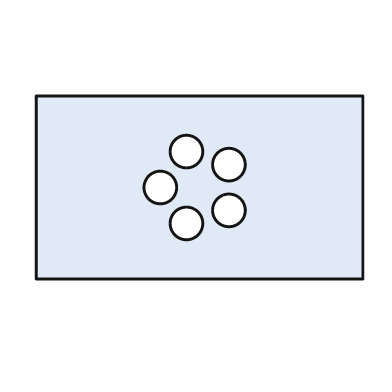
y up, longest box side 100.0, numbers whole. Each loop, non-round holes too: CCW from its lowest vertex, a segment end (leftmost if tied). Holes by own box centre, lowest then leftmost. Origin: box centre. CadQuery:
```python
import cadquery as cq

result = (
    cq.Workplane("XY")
    .moveTo(-50.0, -28.0)
    .lineTo(50.0, -28.0)
    .lineTo(50.0, 28.0)
    .lineTo(-50.0, 28.0)
    .close()
    .moveTo(-4.0, -11.0)
    .circle(5.0)
    .moveTo(9.0, -7.0)
    .circle(5.0)
    .moveTo(-12.0, 0.0)
    .circle(5.0)
    .moveTo(9.0, 7.0)
    .circle(5.0)
    .moveTo(-4.0, 11.0)
    .circle(5.0)
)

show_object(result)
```